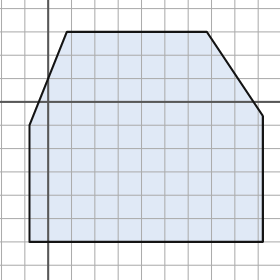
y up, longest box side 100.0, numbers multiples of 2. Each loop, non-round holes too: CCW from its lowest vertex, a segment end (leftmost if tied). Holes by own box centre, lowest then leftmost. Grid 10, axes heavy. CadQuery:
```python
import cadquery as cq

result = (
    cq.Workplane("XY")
    .moveTo(-8.0, -60.0)
    .lineTo(92.0, -60.0)
    .lineTo(92.0, -6.0)
    .lineTo(68.0, 30.0)
    .lineTo(8.0, 30.0)
    .lineTo(-8.0, -10.0)
    .close()
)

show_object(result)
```